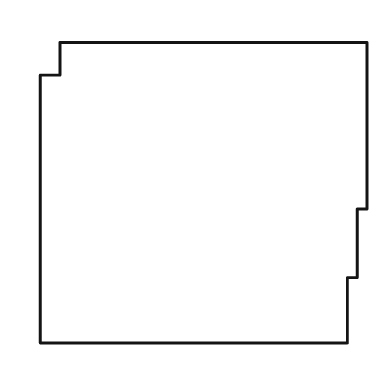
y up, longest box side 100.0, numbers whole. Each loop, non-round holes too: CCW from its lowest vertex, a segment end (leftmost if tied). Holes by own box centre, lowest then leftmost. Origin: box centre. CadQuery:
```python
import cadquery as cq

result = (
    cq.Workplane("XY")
    .moveTo(-50.0, -46.0)
    .lineTo(44.0, -46.0)
    .lineTo(44.0, -26.0)
    .lineTo(47.0, -26.0)
    .lineTo(47.0, -5.0)
    .lineTo(50.0, -5.0)
    .lineTo(50.0, 46.0)
    .lineTo(-44.0, 46.0)
    .lineTo(-44.0, 36.0)
    .lineTo(-50.0, 36.0)
    .close()
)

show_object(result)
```